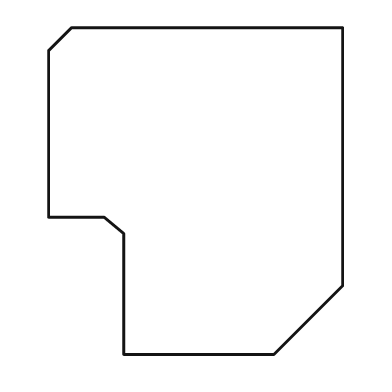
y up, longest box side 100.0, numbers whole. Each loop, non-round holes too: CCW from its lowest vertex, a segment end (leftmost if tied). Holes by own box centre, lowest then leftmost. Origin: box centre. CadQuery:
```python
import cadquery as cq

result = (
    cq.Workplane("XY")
    .moveTo(-22.0, -50.0)
    .lineTo(24.0, -50.0)
    .lineTo(45.0, -29.0)
    .lineTo(45.0, 50.0)
    .lineTo(-38.0, 50.0)
    .lineTo(-45.0, 43.0)
    .lineTo(-45.0, -8.0)
    .lineTo(-28.0, -8.0)
    .lineTo(-22.0, -13.0)
    .close()
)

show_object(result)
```